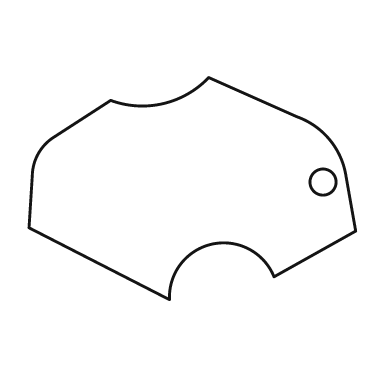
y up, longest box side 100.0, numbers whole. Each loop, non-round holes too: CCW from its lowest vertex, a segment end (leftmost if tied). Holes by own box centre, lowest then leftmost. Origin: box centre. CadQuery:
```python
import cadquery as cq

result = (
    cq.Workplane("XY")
    .moveTo(-7.0, -34.0)
    .threePointArc((6.0, -17.0), (25.0, -27.0))
    .lineTo(50.0, -13.0)
    .lineTo(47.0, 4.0)
    .threePointArc((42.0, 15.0), (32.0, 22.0))
    .lineTo(5.0, 34.0)
    .threePointArc((-9.0, 26.0), (-25.0, 27.0))
    .lineTo(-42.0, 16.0)
    .threePointArc((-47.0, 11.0), (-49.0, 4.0))
    .lineTo(-50.0, -12.0)
    .close()
    .moveTo(40.0, 2.0)
    .circle(4.0)
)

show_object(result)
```